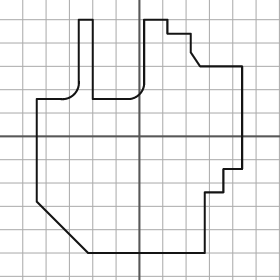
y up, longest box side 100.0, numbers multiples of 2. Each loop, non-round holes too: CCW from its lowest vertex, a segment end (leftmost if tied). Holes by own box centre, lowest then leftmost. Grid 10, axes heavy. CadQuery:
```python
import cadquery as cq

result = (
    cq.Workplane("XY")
    .moveTo(-22.0, -50.0)
    .lineTo(28.0, -50.0)
    .lineTo(28.0, -24.0)
    .lineTo(36.0, -24.0)
    .lineTo(36.0, -14.0)
    .lineTo(44.0, -14.0)
    .lineTo(44.0, 30.0)
    .lineTo(26.0, 30.0)
    .lineTo(22.0, 36.0)
    .lineTo(22.0, 44.0)
    .lineTo(12.0, 44.0)
    .lineTo(12.0, 50.0)
    .lineTo(2.0, 50.0)
    .lineTo(2.0, 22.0)
    .threePointArc((0.0, 18.0), (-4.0, 16.0))
    .lineTo(-20.0, 16.0)
    .lineTo(-20.0, 50.0)
    .lineTo(-26.0, 50.0)
    .lineTo(-26.0, 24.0)
    .threePointArc((-28.0, 18.0), (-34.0, 16.0))
    .lineTo(-44.0, 16.0)
    .lineTo(-44.0, -28.0)
    .close()
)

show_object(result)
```